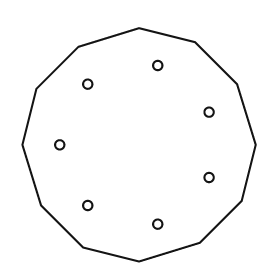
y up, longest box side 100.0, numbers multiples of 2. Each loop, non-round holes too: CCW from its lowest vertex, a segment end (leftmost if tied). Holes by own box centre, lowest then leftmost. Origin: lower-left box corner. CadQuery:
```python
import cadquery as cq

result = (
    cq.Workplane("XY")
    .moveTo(50.0, 0.0)
    .lineTo(76.0, 8.0)
    .lineTo(94.0, 26.0)
    .lineTo(100.0, 50.0)
    .lineTo(92.0, 76.0)
    .lineTo(74.0, 94.0)
    .lineTo(50.0, 100.0)
    .lineTo(24.0, 92.0)
    .lineTo(6.0, 74.0)
    .lineTo(0.0, 50.0)
    .lineTo(8.0, 24.0)
    .lineTo(26.0, 6.0)
    .close()
    .moveTo(58.0, 16.0)
    .circle(2.0)
    .moveTo(28.0, 24.0)
    .circle(2.0)
    .moveTo(80.0, 36.0)
    .circle(2.0)
    .moveTo(16.0, 50.0)
    .circle(2.0)
    .moveTo(80.0, 64.0)
    .circle(2.0)
    .moveTo(28.0, 76.0)
    .circle(2.0)
    .moveTo(58.0, 84.0)
    .circle(2.0)
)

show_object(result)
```